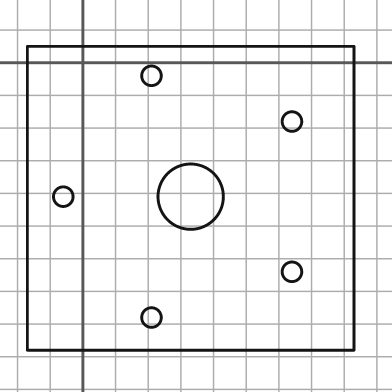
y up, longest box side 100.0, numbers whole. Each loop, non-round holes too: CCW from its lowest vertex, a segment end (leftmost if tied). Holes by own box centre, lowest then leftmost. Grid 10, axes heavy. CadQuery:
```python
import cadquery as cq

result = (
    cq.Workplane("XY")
    .moveTo(-17.0, -88.0)
    .lineTo(83.0, -88.0)
    .lineTo(83.0, 5.0)
    .lineTo(-17.0, 5.0)
    .close()
    .moveTo(21.0, -78.0)
    .circle(3.0)
    .moveTo(64.0, -64.0)
    .circle(3.0)
    .moveTo(-6.0, -41.0)
    .circle(3.0)
    .moveTo(33.0, -41.0)
    .circle(10.0)
    .moveTo(64.0, -18.0)
    .circle(3.0)
    .moveTo(21.0, -4.0)
    .circle(3.0)
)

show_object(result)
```